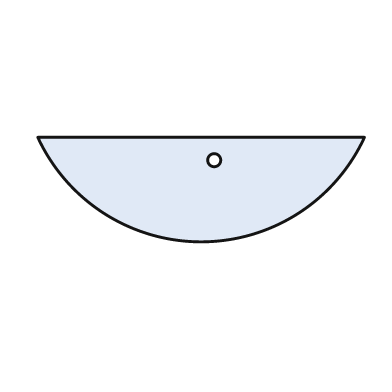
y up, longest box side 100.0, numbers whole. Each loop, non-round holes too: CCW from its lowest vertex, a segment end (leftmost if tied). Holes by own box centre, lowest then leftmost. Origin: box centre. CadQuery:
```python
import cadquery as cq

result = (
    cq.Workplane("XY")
    .moveTo(-50.0, 16.0)
    .threePointArc((0.0, -16.0), (50.0, 16.0))
    .close()
    .moveTo(4.0, 9.0)
    .circle(2.0)
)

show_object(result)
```